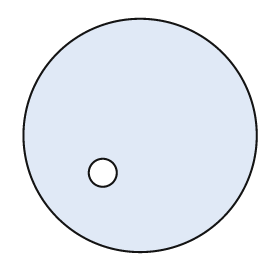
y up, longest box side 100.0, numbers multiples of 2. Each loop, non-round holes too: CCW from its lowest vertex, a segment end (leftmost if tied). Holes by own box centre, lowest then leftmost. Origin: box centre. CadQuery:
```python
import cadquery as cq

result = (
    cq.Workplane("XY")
    .moveTo(0.0, 0.0)
    .circle(50.0)
    .moveTo(-16.0, -16.0)
    .circle(6.0)
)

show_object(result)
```